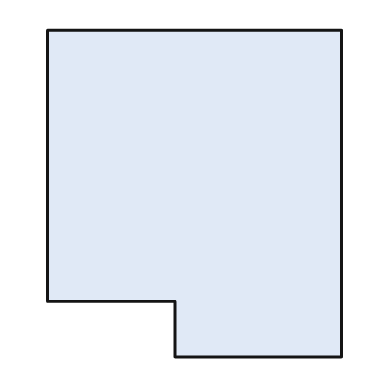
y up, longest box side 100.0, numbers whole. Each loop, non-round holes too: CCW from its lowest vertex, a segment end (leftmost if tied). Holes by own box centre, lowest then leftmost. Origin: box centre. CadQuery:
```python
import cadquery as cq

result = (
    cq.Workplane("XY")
    .moveTo(-6.0, -50.0)
    .lineTo(45.0, -50.0)
    .lineTo(45.0, 50.0)
    .lineTo(-45.0, 50.0)
    .lineTo(-45.0, -33.0)
    .lineTo(-6.0, -33.0)
    .close()
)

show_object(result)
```